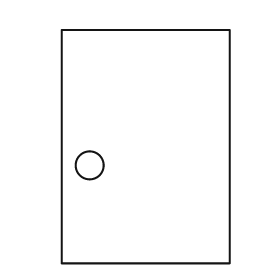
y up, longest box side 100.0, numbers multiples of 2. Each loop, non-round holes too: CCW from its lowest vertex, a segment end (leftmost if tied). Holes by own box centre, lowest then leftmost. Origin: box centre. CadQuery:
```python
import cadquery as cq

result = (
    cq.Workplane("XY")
    .moveTo(-36.0, -50.0)
    .lineTo(36.0, -50.0)
    .lineTo(36.0, 50.0)
    .lineTo(-36.0, 50.0)
    .close()
    .moveTo(-24.0, -8.0)
    .circle(6.0)
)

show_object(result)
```